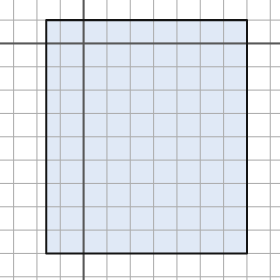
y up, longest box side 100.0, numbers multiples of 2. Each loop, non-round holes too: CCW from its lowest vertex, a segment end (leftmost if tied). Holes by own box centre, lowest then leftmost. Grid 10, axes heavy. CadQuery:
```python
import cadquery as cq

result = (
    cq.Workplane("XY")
    .moveTo(-16.0, -90.0)
    .lineTo(70.0, -90.0)
    .lineTo(70.0, 10.0)
    .lineTo(-16.0, 10.0)
    .close()
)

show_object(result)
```